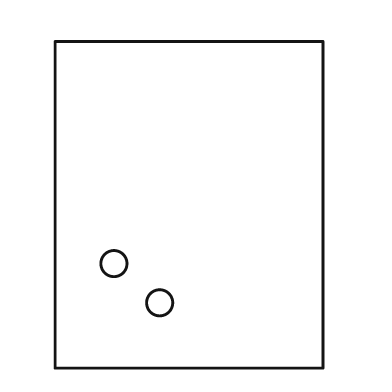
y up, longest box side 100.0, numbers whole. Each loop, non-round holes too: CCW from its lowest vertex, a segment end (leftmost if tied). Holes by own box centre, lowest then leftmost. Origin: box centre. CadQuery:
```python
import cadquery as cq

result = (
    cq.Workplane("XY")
    .moveTo(-41.0, -50.0)
    .lineTo(41.0, -50.0)
    .lineTo(41.0, 50.0)
    .lineTo(-41.0, 50.0)
    .close()
    .moveTo(-9.0, -30.0)
    .circle(4.0)
    .moveTo(-23.0, -18.0)
    .circle(4.0)
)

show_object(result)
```